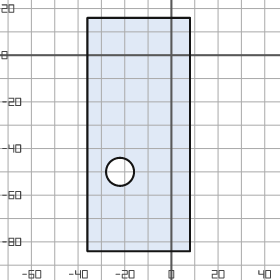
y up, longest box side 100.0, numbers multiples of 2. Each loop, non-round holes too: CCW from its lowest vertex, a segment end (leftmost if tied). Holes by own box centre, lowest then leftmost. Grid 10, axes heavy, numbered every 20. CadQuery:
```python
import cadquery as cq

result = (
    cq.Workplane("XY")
    .moveTo(-36.0, -84.0)
    .lineTo(8.0, -84.0)
    .lineTo(8.0, 16.0)
    .lineTo(-36.0, 16.0)
    .close()
    .moveTo(-22.0, -50.0)
    .circle(6.0)
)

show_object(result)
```